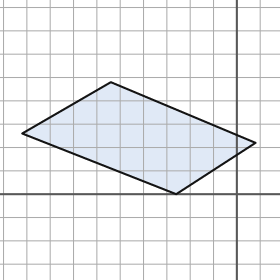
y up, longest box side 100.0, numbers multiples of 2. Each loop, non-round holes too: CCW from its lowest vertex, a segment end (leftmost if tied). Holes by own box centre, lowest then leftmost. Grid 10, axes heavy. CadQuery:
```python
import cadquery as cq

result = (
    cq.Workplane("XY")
    .moveTo(-26.0, 0.0)
    .lineTo(8.0, 22.0)
    .lineTo(-54.0, 48.0)
    .lineTo(-92.0, 26.0)
    .close()
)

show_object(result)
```